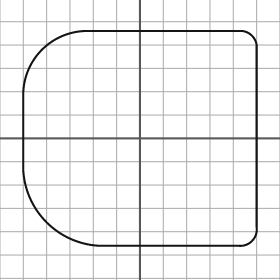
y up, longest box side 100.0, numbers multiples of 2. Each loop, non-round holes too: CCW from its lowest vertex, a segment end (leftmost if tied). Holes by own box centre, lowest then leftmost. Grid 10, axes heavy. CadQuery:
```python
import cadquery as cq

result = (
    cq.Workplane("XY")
    .moveTo(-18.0, -46.0)
    .lineTo(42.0, -46.0)
    .threePointArc((48.0, -44.0), (50.0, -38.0))
    .lineTo(50.0, 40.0)
    .threePointArc((48.0, 44.0), (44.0, 46.0))
    .lineTo(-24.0, 46.0)
    .threePointArc((-42.0, 38.0), (-50.0, 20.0))
    .lineTo(-50.0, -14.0)
    .threePointArc((-40.0, -36.0), (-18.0, -46.0))
    .close()
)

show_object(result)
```